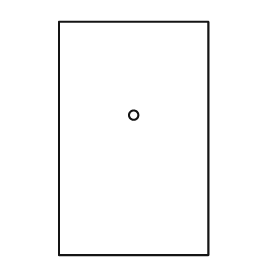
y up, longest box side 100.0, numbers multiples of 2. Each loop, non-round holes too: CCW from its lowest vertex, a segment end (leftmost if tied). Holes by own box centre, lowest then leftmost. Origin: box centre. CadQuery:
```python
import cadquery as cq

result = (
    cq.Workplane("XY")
    .moveTo(-32.0, -50.0)
    .lineTo(32.0, -50.0)
    .lineTo(32.0, 50.0)
    .lineTo(-32.0, 50.0)
    .close()
    .moveTo(0.0, 10.0)
    .circle(2.0)
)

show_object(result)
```